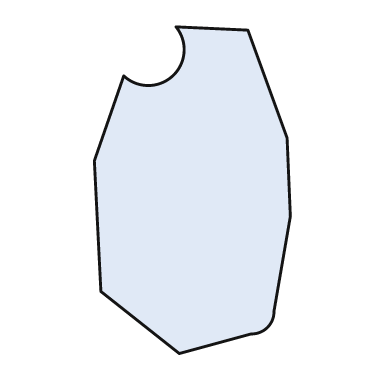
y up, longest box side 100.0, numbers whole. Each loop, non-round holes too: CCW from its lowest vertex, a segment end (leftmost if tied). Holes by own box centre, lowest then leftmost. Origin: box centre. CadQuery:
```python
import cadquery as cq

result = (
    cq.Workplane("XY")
    .moveTo(-4.0, -50.0)
    .lineTo(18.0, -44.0)
    .threePointArc((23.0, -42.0), (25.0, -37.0))
    .lineTo(30.0, -8.0)
    .lineTo(29.0, 16.0)
    .lineTo(17.0, 49.0)
    .lineTo(-5.0, 50.0)
    .threePointArc((-6.0, 35.0), (-21.0, 35.0))
    .lineTo(-30.0, 9.0)
    .lineTo(-28.0, -31.0)
    .close()
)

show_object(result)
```